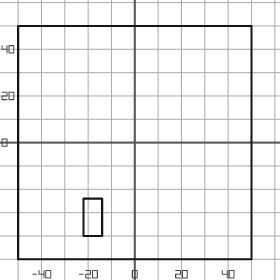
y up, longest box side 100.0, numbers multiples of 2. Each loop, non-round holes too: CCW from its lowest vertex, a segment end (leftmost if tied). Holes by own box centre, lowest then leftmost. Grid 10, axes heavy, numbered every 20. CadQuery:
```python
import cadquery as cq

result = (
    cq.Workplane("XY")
    .moveTo(-50.0, -50.0)
    .lineTo(50.0, -50.0)
    .lineTo(50.0, 50.0)
    .lineTo(-50.0, 50.0)
    .close()
    .moveTo(-22.0, -40.0)
    .lineTo(-14.0, -40.0)
    .lineTo(-14.0, -24.0)
    .lineTo(-22.0, -24.0)
    .close()
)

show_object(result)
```